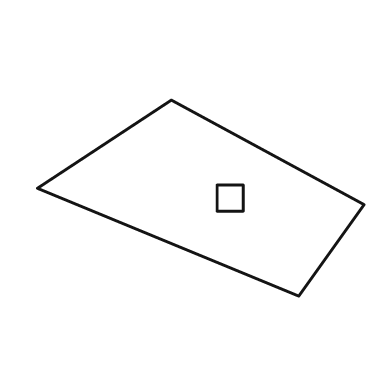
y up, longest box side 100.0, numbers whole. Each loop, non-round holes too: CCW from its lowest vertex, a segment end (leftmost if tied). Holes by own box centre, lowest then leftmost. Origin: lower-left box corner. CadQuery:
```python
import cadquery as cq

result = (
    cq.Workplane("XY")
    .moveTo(80.0, 0.0)
    .lineTo(100.0, 28.0)
    .lineTo(41.0, 60.0)
    .lineTo(0.0, 33.0)
    .close()
    .moveTo(55.0, 26.0)
    .lineTo(63.0, 26.0)
    .lineTo(63.0, 34.0)
    .lineTo(55.0, 34.0)
    .close()
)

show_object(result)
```